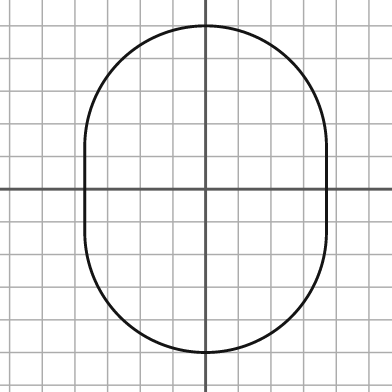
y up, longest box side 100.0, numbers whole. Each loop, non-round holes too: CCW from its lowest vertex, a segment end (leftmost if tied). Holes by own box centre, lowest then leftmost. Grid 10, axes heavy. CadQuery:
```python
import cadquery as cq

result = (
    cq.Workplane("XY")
    .moveTo(-37.0, -13.0)
    .threePointArc((0.0, -50.0), (37.0, -13.0))
    .lineTo(37.0, 13.0)
    .threePointArc((0.0, 50.0), (-37.0, 13.0))
    .close()
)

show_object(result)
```